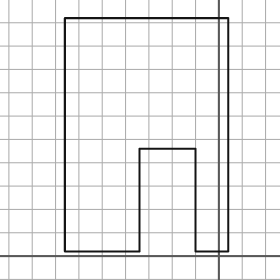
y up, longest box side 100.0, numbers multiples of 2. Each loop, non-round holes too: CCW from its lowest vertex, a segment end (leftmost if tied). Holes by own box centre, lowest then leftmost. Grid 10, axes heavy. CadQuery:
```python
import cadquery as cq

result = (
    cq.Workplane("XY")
    .moveTo(-66.0, 2.0)
    .lineTo(-34.0, 2.0)
    .lineTo(-34.0, 46.0)
    .lineTo(-10.0, 46.0)
    .lineTo(-10.0, 2.0)
    .lineTo(4.0, 2.0)
    .lineTo(4.0, 102.0)
    .lineTo(-66.0, 102.0)
    .close()
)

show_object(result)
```